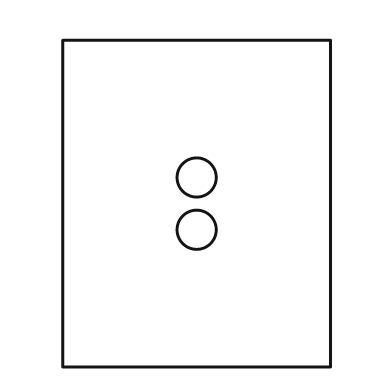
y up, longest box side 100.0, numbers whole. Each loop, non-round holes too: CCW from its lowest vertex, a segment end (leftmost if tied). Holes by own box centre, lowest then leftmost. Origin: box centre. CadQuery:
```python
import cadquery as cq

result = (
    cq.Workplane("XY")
    .moveTo(-41.0, -50.0)
    .lineTo(41.0, -50.0)
    .lineTo(41.0, 50.0)
    .lineTo(-41.0, 50.0)
    .close()
    .moveTo(0.0, -8.0)
    .circle(6.0)
    .moveTo(0.0, 8.0)
    .circle(6.0)
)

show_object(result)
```